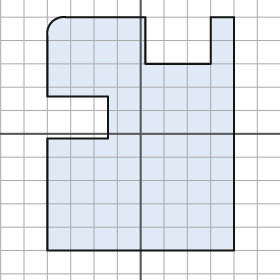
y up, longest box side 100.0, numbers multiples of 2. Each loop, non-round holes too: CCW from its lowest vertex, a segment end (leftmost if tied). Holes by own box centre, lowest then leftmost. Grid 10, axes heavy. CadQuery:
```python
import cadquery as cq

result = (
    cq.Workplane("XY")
    .moveTo(-40.0, -50.0)
    .lineTo(40.0, -50.0)
    .lineTo(40.0, 50.0)
    .lineTo(30.0, 50.0)
    .lineTo(30.0, 30.0)
    .lineTo(2.0, 30.0)
    .lineTo(2.0, 50.0)
    .lineTo(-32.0, 50.0)
    .threePointArc((-38.0, 48.0), (-40.0, 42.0))
    .lineTo(-40.0, 16.0)
    .lineTo(-14.0, 16.0)
    .lineTo(-14.0, -2.0)
    .lineTo(-40.0, -2.0)
    .close()
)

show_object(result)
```